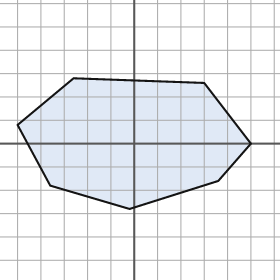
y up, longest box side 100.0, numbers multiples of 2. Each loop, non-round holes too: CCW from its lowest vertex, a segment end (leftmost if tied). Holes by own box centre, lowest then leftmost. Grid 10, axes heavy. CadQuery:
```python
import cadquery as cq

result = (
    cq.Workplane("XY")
    .moveTo(-2.0, -28.0)
    .lineTo(36.0, -16.0)
    .lineTo(50.0, 0.0)
    .lineTo(30.0, 26.0)
    .lineTo(-26.0, 28.0)
    .lineTo(-50.0, 8.0)
    .lineTo(-36.0, -18.0)
    .close()
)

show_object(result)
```